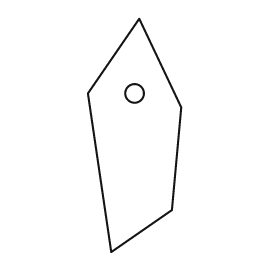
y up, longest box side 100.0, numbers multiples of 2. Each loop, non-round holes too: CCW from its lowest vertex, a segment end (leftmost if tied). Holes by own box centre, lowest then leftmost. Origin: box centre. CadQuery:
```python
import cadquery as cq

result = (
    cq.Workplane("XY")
    .moveTo(-10.0, -50.0)
    .lineTo(16.0, -32.0)
    .lineTo(20.0, 12.0)
    .lineTo(2.0, 50.0)
    .lineTo(-20.0, 18.0)
    .close()
    .moveTo(0.0, 18.0)
    .circle(4.0)
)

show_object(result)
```